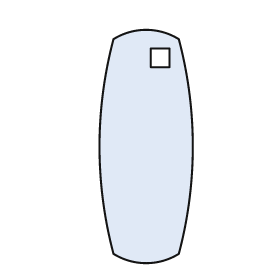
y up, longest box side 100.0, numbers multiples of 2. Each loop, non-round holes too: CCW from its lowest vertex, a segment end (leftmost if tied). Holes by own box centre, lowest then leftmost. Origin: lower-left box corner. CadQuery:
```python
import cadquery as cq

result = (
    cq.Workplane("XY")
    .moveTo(6.0, 4.0)
    .threePointArc((20.0, 0.0), (34.0, 4.0))
    .threePointArc((40.0, 50.0), (34.0, 96.0))
    .threePointArc((20.0, 100.0), (6.0, 96.0))
    .threePointArc((0.0, 50.0), (6.0, 4.0))
    .close()
    .moveTo(22.0, 84.0)
    .lineTo(30.0, 84.0)
    .lineTo(30.0, 92.0)
    .lineTo(22.0, 92.0)
    .close()
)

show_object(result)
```